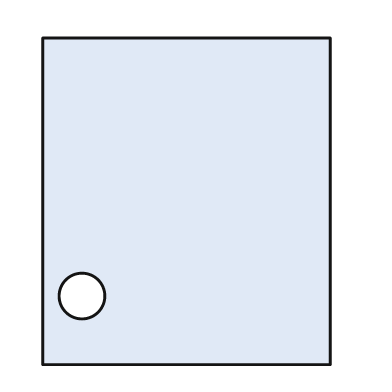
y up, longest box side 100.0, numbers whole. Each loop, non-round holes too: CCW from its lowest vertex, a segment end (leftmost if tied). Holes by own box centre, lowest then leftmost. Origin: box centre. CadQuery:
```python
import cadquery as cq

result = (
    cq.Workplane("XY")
    .moveTo(-44.0, -50.0)
    .lineTo(44.0, -50.0)
    .lineTo(44.0, 50.0)
    .lineTo(-44.0, 50.0)
    .close()
    .moveTo(-32.0, -29.0)
    .circle(7.0)
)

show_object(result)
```